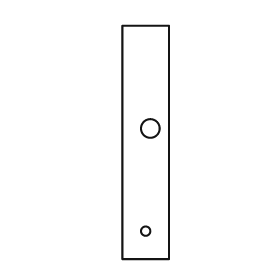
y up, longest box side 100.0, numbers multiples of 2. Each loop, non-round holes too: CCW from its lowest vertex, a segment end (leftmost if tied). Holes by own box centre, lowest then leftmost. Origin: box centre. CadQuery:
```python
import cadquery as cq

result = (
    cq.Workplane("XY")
    .moveTo(-10.0, -50.0)
    .lineTo(10.0, -50.0)
    .lineTo(10.0, 50.0)
    .lineTo(-10.0, 50.0)
    .close()
    .moveTo(0.0, -38.0)
    .circle(2.0)
    .moveTo(2.0, 6.0)
    .circle(4.0)
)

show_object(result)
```